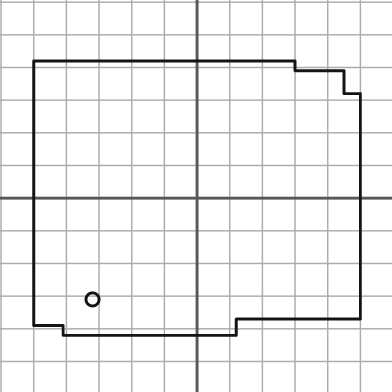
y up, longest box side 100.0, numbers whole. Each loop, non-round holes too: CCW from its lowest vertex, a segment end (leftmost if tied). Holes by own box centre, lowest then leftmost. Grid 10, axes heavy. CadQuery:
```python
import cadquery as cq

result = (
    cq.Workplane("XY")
    .moveTo(-41.0, -42.0)
    .lineTo(12.0, -42.0)
    .lineTo(12.0, -37.0)
    .lineTo(50.0, -37.0)
    .lineTo(50.0, 32.0)
    .lineTo(45.0, 32.0)
    .lineTo(45.0, 39.0)
    .lineTo(30.0, 39.0)
    .lineTo(30.0, 42.0)
    .lineTo(-50.0, 42.0)
    .lineTo(-50.0, -39.0)
    .lineTo(-41.0, -39.0)
    .close()
    .moveTo(-32.0, -31.0)
    .circle(2.0)
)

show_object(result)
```